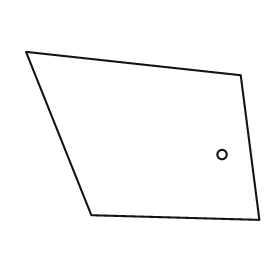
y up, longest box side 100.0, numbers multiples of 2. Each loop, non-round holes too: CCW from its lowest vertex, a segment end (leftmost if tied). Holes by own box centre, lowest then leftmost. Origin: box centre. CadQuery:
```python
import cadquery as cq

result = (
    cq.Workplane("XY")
    .moveTo(50.0, -36.0)
    .lineTo(42.0, 26.0)
    .lineTo(-50.0, 36.0)
    .lineTo(-22.0, -34.0)
    .close()
    .moveTo(34.0, -8.0)
    .circle(2.0)
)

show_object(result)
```